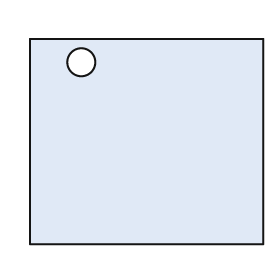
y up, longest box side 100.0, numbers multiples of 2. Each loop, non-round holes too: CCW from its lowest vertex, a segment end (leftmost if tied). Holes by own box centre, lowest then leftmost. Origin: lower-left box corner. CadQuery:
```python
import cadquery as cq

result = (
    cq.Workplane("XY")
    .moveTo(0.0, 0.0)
    .lineTo(100.0, 0.0)
    .lineTo(100.0, 88.0)
    .lineTo(0.0, 88.0)
    .close()
    .moveTo(22.0, 78.0)
    .circle(6.0)
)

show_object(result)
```